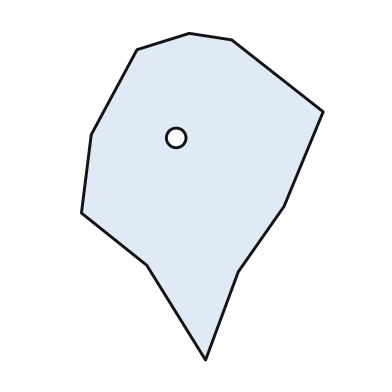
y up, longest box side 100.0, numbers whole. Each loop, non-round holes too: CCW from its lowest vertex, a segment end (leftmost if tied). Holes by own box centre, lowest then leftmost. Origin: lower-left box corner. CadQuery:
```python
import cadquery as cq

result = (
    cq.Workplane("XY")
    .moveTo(38.0, 0.0)
    .lineTo(48.0, 27.0)
    .lineTo(62.0, 47.0)
    .lineTo(74.0, 76.0)
    .lineTo(46.0, 98.0)
    .lineTo(33.0, 100.0)
    .lineTo(17.0, 95.0)
    .lineTo(3.0, 69.0)
    .lineTo(0.0, 45.0)
    .lineTo(20.0, 29.0)
    .close()
    .moveTo(29.0, 68.0)
    .circle(3.0)
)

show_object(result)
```